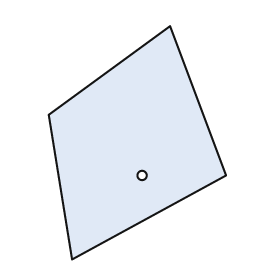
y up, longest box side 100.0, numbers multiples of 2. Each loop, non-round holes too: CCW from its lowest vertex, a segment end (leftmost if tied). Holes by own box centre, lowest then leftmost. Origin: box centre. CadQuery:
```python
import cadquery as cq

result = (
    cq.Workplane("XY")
    .moveTo(-28.0, -50.0)
    .lineTo(38.0, -14.0)
    .lineTo(14.0, 50.0)
    .lineTo(-38.0, 12.0)
    .close()
    .moveTo(2.0, -14.0)
    .circle(2.0)
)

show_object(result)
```